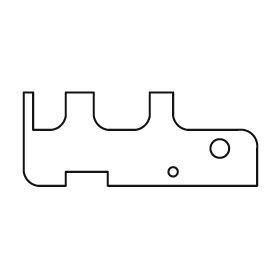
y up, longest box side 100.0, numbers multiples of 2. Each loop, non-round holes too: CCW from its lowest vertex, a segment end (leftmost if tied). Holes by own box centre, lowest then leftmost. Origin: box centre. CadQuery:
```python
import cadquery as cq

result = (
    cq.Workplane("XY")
    .moveTo(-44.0, -20.0)
    .lineTo(-32.0, -20.0)
    .lineTo(-32.0, -14.0)
    .lineTo(-14.0, -14.0)
    .lineTo(-14.0, -20.0)
    .lineTo(50.0, -20.0)
    .lineTo(50.0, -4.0)
    .threePointArc((48.0, 2.0), (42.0, 4.0))
    .lineTo(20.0, 4.0)
    .threePointArc((16.0, 6.0), (14.0, 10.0))
    .lineTo(14.0, 20.0)
    .lineTo(4.0, 20.0)
    .lineTo(4.0, 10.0)
    .threePointArc((2.0, 6.0), (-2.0, 4.0))
    .lineTo(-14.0, 4.0)
    .threePointArc((-18.0, 6.0), (-20.0, 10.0))
    .lineTo(-20.0, 20.0)
    .lineTo(-32.0, 20.0)
    .lineTo(-32.0, 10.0)
    .threePointArc((-34.0, 6.0), (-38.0, 4.0))
    .lineTo(-46.0, 4.0)
    .lineTo(-46.0, 20.0)
    .lineTo(-50.0, 20.0)
    .lineTo(-50.0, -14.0)
    .threePointArc((-48.0, -18.0), (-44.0, -20.0))
    .close()
    .moveTo(14.0, -14.0)
    .circle(2.0)
    .moveTo(34.0, -4.0)
    .circle(4.0)
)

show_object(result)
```